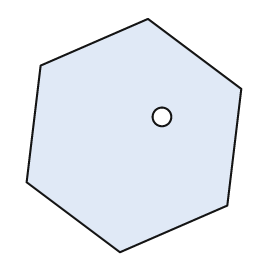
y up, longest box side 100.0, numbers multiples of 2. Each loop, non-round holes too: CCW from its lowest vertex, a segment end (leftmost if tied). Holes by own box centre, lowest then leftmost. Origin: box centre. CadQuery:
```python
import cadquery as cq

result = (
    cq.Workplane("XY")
    .moveTo(-6.0, -50.0)
    .lineTo(40.0, -30.0)
    .lineTo(46.0, 20.0)
    .lineTo(6.0, 50.0)
    .lineTo(-40.0, 30.0)
    .lineTo(-46.0, -20.0)
    .close()
    .moveTo(12.0, 8.0)
    .circle(4.0)
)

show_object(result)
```